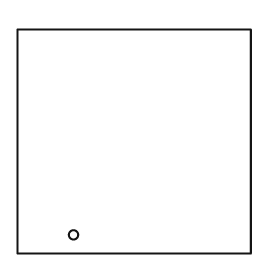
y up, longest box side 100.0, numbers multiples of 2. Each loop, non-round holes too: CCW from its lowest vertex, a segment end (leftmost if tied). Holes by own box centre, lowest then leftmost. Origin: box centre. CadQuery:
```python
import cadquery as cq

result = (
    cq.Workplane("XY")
    .moveTo(-50.0, -48.0)
    .lineTo(50.0, -48.0)
    .lineTo(50.0, 48.0)
    .lineTo(-50.0, 48.0)
    .close()
    .moveTo(-26.0, -40.0)
    .circle(2.0)
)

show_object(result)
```